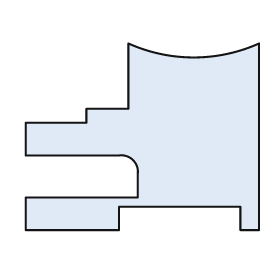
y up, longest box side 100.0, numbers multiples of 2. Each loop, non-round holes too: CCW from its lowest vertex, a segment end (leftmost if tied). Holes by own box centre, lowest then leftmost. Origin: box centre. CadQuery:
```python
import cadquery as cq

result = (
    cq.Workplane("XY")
    .moveTo(-50.0, -40.0)
    .lineTo(-10.0, -40.0)
    .lineTo(-10.0, -30.0)
    .lineTo(42.0, -30.0)
    .lineTo(42.0, -40.0)
    .lineTo(50.0, -40.0)
    .lineTo(50.0, 40.0)
    .threePointArc((22.0, 34.0), (-6.0, 40.0))
    .lineTo(-6.0, 12.0)
    .lineTo(-24.0, 12.0)
    .lineTo(-24.0, 6.0)
    .lineTo(-50.0, 6.0)
    .lineTo(-50.0, -8.0)
    .lineTo(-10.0, -8.0)
    .threePointArc((-4.0, -10.0), (-2.0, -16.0))
    .lineTo(-2.0, -26.0)
    .lineTo(-50.0, -26.0)
    .close()
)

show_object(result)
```